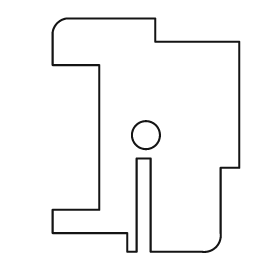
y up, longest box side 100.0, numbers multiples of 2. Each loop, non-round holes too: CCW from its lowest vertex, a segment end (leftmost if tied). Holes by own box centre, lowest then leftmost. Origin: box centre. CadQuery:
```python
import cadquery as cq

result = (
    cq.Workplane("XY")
    .moveTo(-8.0, -50.0)
    .lineTo(-4.0, -50.0)
    .lineTo(-4.0, -10.0)
    .lineTo(2.0, -10.0)
    .lineTo(2.0, -50.0)
    .lineTo(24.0, -50.0)
    .threePointArc((30.0, -48.0), (32.0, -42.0))
    .lineTo(32.0, -14.0)
    .lineTo(40.0, -14.0)
    .lineTo(40.0, 40.0)
    .lineTo(4.0, 40.0)
    .lineTo(4.0, 50.0)
    .lineTo(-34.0, 50.0)
    .threePointArc((-38.0, 48.0), (-40.0, 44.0))
    .lineTo(-40.0, 30.0)
    .lineTo(-20.0, 30.0)
    .lineTo(-20.0, -32.0)
    .lineTo(-40.0, -32.0)
    .lineTo(-40.0, -42.0)
    .lineTo(-8.0, -42.0)
    .close()
    .moveTo(0.0, 0.0)
    .circle(6.0)
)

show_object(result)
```